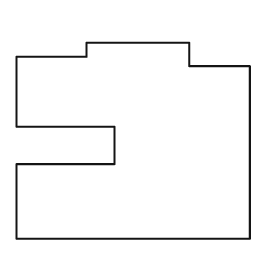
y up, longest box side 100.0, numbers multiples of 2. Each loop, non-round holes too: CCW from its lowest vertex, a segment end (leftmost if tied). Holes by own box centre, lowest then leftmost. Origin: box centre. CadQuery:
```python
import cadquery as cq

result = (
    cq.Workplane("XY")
    .moveTo(-50.0, -42.0)
    .lineTo(50.0, -42.0)
    .lineTo(50.0, 32.0)
    .lineTo(24.0, 32.0)
    .lineTo(24.0, 42.0)
    .lineTo(-20.0, 42.0)
    .lineTo(-20.0, 36.0)
    .lineTo(-50.0, 36.0)
    .lineTo(-50.0, 6.0)
    .lineTo(-8.0, 6.0)
    .lineTo(-8.0, -10.0)
    .lineTo(-50.0, -10.0)
    .close()
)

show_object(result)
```